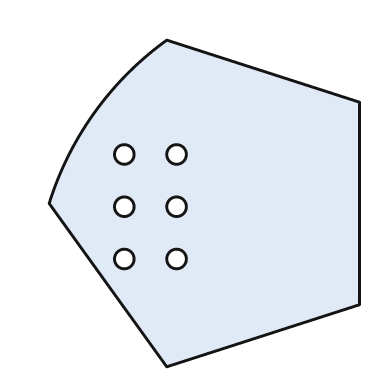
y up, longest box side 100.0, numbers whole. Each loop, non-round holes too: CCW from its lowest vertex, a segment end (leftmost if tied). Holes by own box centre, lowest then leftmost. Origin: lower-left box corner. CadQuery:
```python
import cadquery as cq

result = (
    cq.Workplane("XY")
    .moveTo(36.0, 0.0)
    .lineTo(95.0, 19.0)
    .lineTo(95.0, 81.0)
    .lineTo(36.0, 100.0)
    .threePointArc((14.0, 78.0), (0.0, 50.0))
    .close()
    .moveTo(23.0, 33.0)
    .circle(3.0)
    .moveTo(39.0, 33.0)
    .circle(3.0)
    .moveTo(23.0, 49.0)
    .circle(3.0)
    .moveTo(39.0, 49.0)
    .circle(3.0)
    .moveTo(23.0, 65.0)
    .circle(3.0)
    .moveTo(39.0, 65.0)
    .circle(3.0)
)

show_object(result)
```